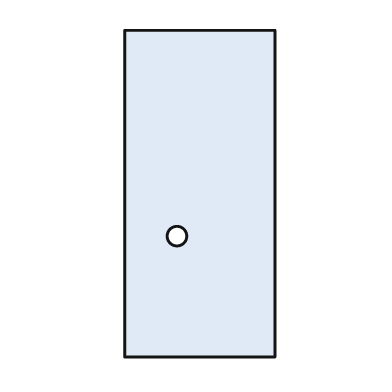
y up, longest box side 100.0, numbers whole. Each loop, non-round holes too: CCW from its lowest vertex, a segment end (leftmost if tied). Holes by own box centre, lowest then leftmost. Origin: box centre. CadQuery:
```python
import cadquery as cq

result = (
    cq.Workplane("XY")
    .moveTo(-23.0, -50.0)
    .lineTo(23.0, -50.0)
    .lineTo(23.0, 50.0)
    .lineTo(-23.0, 50.0)
    .close()
    .moveTo(-7.0, -13.0)
    .circle(3.0)
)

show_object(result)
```